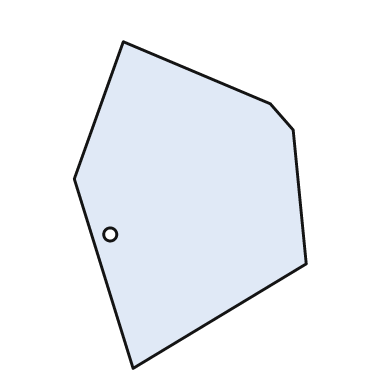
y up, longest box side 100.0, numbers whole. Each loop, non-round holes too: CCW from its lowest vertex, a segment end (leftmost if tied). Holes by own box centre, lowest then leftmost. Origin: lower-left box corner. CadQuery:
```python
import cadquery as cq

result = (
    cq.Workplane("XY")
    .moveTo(18.0, 0.0)
    .lineTo(71.0, 32.0)
    .lineTo(67.0, 73.0)
    .lineTo(60.0, 81.0)
    .lineTo(15.0, 100.0)
    .lineTo(0.0, 58.0)
    .close()
    .moveTo(11.0, 41.0)
    .circle(2.0)
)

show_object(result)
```